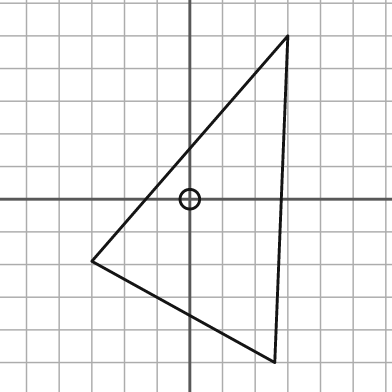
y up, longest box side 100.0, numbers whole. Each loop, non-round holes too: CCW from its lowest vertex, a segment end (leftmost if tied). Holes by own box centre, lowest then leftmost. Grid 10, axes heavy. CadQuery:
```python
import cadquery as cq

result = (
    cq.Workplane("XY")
    .moveTo(26.0, -50.0)
    .lineTo(30.0, 50.0)
    .lineTo(-30.0, -19.0)
    .close()
    .moveTo(0.0, 0.0)
    .circle(3.0)
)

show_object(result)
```